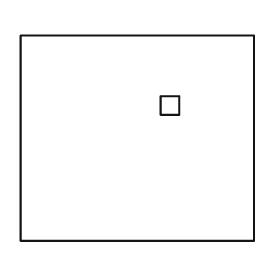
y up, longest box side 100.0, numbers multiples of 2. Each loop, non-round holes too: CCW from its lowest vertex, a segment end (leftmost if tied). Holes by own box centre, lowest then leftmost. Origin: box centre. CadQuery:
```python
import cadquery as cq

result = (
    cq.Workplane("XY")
    .moveTo(-50.0, -44.0)
    .lineTo(50.0, -44.0)
    .lineTo(50.0, 44.0)
    .lineTo(-50.0, 44.0)
    .close()
    .moveTo(10.0, 10.0)
    .lineTo(18.0, 10.0)
    .lineTo(18.0, 18.0)
    .lineTo(10.0, 18.0)
    .close()
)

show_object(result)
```